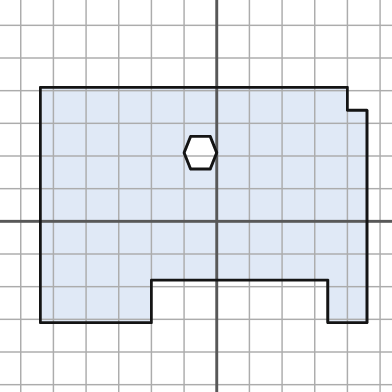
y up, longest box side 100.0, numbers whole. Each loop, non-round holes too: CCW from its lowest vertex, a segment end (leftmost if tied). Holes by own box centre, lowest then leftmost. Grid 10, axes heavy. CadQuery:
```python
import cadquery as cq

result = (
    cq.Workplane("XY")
    .moveTo(-54.0, -31.0)
    .lineTo(-20.0, -31.0)
    .lineTo(-20.0, -18.0)
    .lineTo(34.0, -18.0)
    .lineTo(34.0, -31.0)
    .lineTo(46.0, -31.0)
    .lineTo(46.0, 34.0)
    .lineTo(40.0, 34.0)
    .lineTo(40.0, 41.0)
    .lineTo(-54.0, 41.0)
    .close()
    .moveTo(-8.0, 16.0)
    .lineTo(-2.0, 16.0)
    .lineTo(0.0, 21.0)
    .lineTo(-2.0, 26.0)
    .lineTo(-8.0, 26.0)
    .lineTo(-10.0, 21.0)
    .close()
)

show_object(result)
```